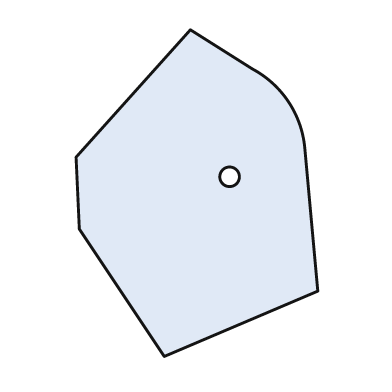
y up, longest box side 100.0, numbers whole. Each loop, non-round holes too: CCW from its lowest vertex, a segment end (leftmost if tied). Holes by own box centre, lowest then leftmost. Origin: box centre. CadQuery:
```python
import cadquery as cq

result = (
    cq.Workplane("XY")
    .moveTo(-10.0, -50.0)
    .lineTo(37.0, -30.0)
    .lineTo(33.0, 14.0)
    .threePointArc((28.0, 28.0), (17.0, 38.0))
    .lineTo(-2.0, 50.0)
    .lineTo(-37.0, 11.0)
    .lineTo(-36.0, -11.0)
    .close()
    .moveTo(10.0, 5.0)
    .circle(3.0)
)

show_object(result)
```